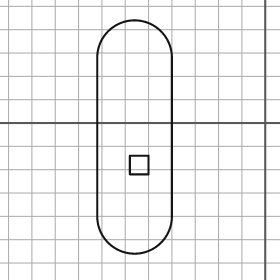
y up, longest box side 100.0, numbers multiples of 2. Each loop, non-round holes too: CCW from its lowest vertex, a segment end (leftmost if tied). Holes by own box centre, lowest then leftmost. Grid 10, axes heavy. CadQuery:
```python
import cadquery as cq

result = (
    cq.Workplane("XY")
    .moveTo(-72.0, -40.0)
    .threePointArc((-56.0, -56.0), (-40.0, -40.0))
    .lineTo(-40.0, 28.0)
    .threePointArc((-56.0, 44.0), (-72.0, 28.0))
    .close()
    .moveTo(-58.0, -22.0)
    .lineTo(-50.0, -22.0)
    .lineTo(-50.0, -14.0)
    .lineTo(-58.0, -14.0)
    .close()
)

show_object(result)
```